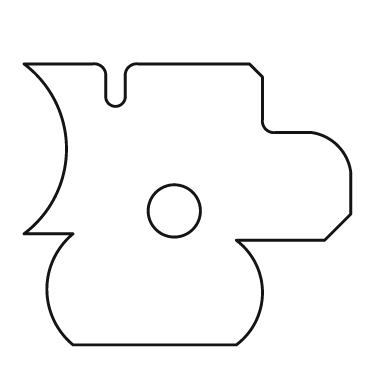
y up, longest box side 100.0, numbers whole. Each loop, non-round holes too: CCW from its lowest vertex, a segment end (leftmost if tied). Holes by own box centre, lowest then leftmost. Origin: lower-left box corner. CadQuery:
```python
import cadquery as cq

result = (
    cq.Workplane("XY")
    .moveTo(15.0, 0.0)
    .lineTo(65.0, 0.0)
    .threePointArc((73.0, 16.0), (65.0, 32.0))
    .lineTo(92.0, 32.0)
    .lineTo(100.0, 40.0)
    .lineTo(100.0, 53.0)
    .threePointArc((96.0, 61.0), (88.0, 65.0))
    .lineTo(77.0, 65.0)
    .threePointArc((74.0, 66.0), (73.0, 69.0))
    .lineTo(73.0, 82.0)
    .lineTo(69.0, 86.0)
    .lineTo(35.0, 86.0)
    .threePointArc((32.0, 85.0), (31.0, 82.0))
    .lineTo(31.0, 76.0)
    .threePointArc((28.0, 73.0), (25.0, 76.0))
    .lineTo(25.0, 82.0)
    .threePointArc((24.0, 85.0), (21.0, 86.0))
    .lineTo(0.0, 86.0)
    .threePointArc((13.0, 60.0), (0.0, 34.0))
    .lineTo(15.0, 34.0)
    .threePointArc((7.0, 17.0), (15.0, 0.0))
    .close()
    .moveTo(46.0, 41.0)
    .circle(8.0)
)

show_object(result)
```